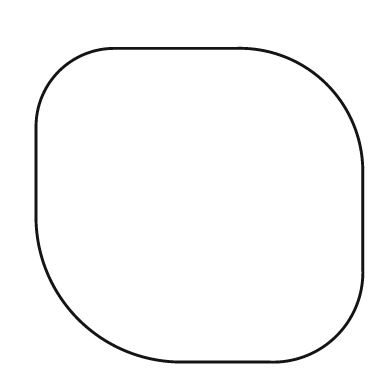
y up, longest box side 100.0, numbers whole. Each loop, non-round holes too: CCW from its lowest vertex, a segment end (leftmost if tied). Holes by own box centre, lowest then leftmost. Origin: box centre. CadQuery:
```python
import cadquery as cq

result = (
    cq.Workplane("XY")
    .moveTo(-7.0, -48.0)
    .lineTo(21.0, -48.0)
    .threePointArc((42.0, -40.0), (50.0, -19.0))
    .lineTo(50.0, 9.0)
    .threePointArc((39.0, 37.0), (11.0, 48.0))
    .lineTo(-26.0, 48.0)
    .threePointArc((-43.0, 41.0), (-50.0, 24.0))
    .lineTo(-50.0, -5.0)
    .threePointArc((-37.0, -35.0), (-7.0, -48.0))
    .close()
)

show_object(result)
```